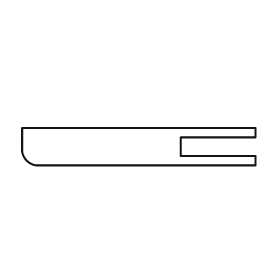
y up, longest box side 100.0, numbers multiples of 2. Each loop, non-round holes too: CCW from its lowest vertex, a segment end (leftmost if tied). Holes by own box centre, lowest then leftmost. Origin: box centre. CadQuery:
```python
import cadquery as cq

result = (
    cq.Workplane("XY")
    .moveTo(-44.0, -8.0)
    .lineTo(50.0, -8.0)
    .lineTo(50.0, -4.0)
    .lineTo(18.0, -4.0)
    .lineTo(18.0, 4.0)
    .lineTo(50.0, 4.0)
    .lineTo(50.0, 8.0)
    .lineTo(-50.0, 8.0)
    .lineTo(-50.0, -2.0)
    .threePointArc((-48.0, -6.0), (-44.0, -8.0))
    .close()
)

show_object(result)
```